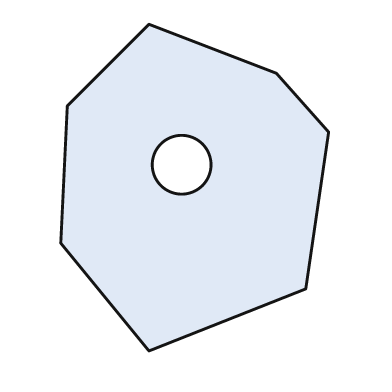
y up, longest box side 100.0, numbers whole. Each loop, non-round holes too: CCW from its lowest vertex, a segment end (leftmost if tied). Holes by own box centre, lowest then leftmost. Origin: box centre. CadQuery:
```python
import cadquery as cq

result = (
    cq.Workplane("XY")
    .moveTo(-14.0, -50.0)
    .lineTo(34.0, -31.0)
    .lineTo(41.0, 17.0)
    .lineTo(25.0, 35.0)
    .lineTo(-14.0, 50.0)
    .lineTo(-39.0, 25.0)
    .lineTo(-41.0, -17.0)
    .close()
    .moveTo(-4.0, 7.0)
    .circle(9.0)
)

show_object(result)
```